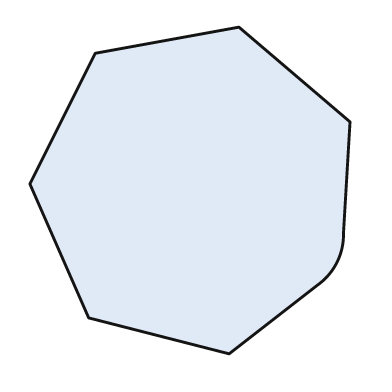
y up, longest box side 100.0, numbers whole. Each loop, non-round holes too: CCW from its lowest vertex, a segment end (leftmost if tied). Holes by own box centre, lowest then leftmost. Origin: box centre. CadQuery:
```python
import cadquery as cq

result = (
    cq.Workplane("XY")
    .moveTo(12.0, -50.0)
    .lineTo(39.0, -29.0)
    .threePointArc((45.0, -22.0), (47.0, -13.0))
    .lineTo(49.0, 21.0)
    .lineTo(15.0, 50.0)
    .lineTo(-29.0, 42.0)
    .lineTo(-49.0, 2.0)
    .lineTo(-31.0, -39.0)
    .close()
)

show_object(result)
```